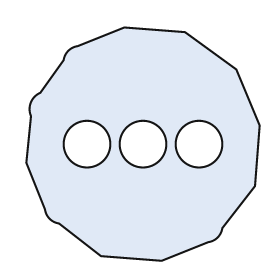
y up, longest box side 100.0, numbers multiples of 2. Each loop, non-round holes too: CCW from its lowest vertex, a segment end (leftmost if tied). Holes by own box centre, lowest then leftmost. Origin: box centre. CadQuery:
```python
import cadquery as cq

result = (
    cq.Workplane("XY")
    .moveTo(8.0, -50.0)
    .lineTo(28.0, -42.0)
    .threePointArc((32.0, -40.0), (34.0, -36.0))
    .lineTo(48.0, -18.0)
    .lineTo(50.0, 8.0)
    .lineTo(40.0, 32.0)
    .lineTo(18.0, 48.0)
    .lineTo(-8.0, 50.0)
    .lineTo(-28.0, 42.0)
    .threePointArc((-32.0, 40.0), (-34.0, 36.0))
    .lineTo(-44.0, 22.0)
    .threePointArc((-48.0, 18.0), (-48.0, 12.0))
    .lineTo(-50.0, -8.0)
    .lineTo(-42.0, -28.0)
    .threePointArc((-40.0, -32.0), (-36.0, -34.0))
    .lineTo(-18.0, -48.0)
    .close()
    .moveTo(-24.0, 0.0)
    .circle(10.0)
    .moveTo(0.0, 0.0)
    .circle(10.0)
    .moveTo(24.0, 0.0)
    .circle(10.0)
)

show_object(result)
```